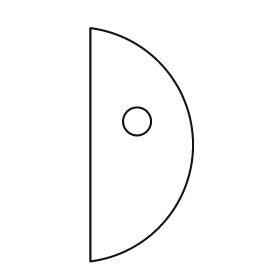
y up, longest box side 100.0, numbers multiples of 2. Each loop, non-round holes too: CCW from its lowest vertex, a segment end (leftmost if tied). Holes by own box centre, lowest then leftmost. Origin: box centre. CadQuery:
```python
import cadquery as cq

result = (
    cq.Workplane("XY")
    .moveTo(-22.0, -50.0)
    .threePointArc((22.0, 0.0), (-22.0, 50.0))
    .close()
    .moveTo(-2.0, 10.0)
    .circle(6.0)
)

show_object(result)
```